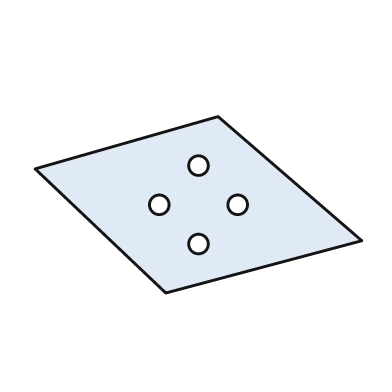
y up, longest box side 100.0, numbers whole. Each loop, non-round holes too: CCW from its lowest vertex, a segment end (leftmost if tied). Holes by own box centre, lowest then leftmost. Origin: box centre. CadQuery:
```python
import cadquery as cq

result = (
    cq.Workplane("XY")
    .moveTo(-10.0, -27.0)
    .lineTo(50.0, -11.0)
    .lineTo(6.0, 27.0)
    .lineTo(-50.0, 11.0)
    .close()
    .moveTo(0.0, -12.0)
    .circle(3.0)
    .moveTo(-12.0, 0.0)
    .circle(3.0)
    .moveTo(12.0, 0.0)
    .circle(3.0)
    .moveTo(0.0, 12.0)
    .circle(3.0)
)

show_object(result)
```